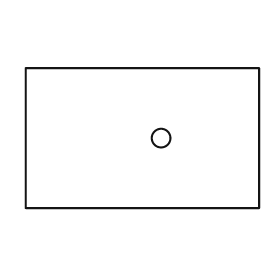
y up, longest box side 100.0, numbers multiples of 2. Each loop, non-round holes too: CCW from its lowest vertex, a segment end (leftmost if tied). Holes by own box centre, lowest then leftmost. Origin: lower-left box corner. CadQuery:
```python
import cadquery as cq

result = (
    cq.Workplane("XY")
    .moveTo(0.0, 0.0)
    .lineTo(100.0, 0.0)
    .lineTo(100.0, 60.0)
    .lineTo(0.0, 60.0)
    .close()
    .moveTo(58.0, 30.0)
    .circle(4.0)
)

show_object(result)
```